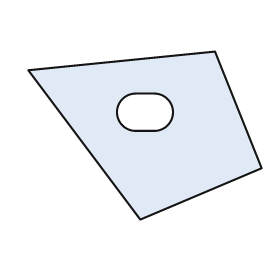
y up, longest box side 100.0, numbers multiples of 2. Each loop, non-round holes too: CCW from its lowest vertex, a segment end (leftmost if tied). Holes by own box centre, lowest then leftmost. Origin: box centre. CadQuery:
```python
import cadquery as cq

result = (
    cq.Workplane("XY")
    .moveTo(-2.0, -36.0)
    .lineTo(50.0, -14.0)
    .lineTo(30.0, 36.0)
    .lineTo(-50.0, 28.0)
    .close()
    .moveTo(-4.0, 2.0)
    .lineTo(4.0, 2.0)
    .threePointArc((12.0, 10.0), (4.0, 18.0))
    .lineTo(-4.0, 18.0)
    .threePointArc((-12.0, 10.0), (-4.0, 2.0))
    .close()
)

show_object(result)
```